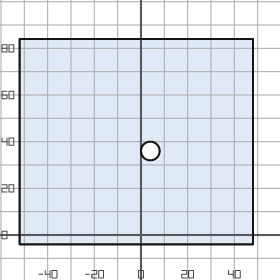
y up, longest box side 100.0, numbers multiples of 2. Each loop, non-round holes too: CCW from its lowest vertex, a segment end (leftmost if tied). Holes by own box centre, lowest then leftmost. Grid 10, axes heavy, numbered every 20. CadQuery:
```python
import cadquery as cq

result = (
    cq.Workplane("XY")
    .moveTo(-52.0, -4.0)
    .lineTo(48.0, -4.0)
    .lineTo(48.0, 84.0)
    .lineTo(-52.0, 84.0)
    .close()
    .moveTo(4.0, 36.0)
    .circle(4.0)
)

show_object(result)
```